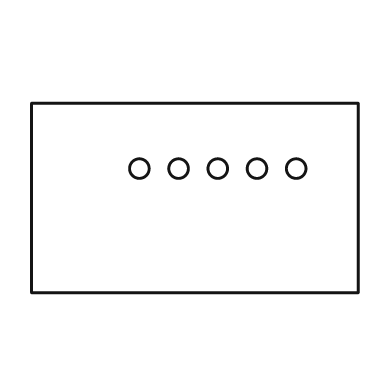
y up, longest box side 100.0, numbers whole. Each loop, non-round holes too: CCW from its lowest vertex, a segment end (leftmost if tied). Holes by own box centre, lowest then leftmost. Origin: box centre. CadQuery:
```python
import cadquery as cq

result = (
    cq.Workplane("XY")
    .moveTo(-50.0, -29.0)
    .lineTo(50.0, -29.0)
    .lineTo(50.0, 29.0)
    .lineTo(-50.0, 29.0)
    .close()
    .moveTo(-17.0, 9.0)
    .circle(3.0)
    .moveTo(-5.0, 9.0)
    .circle(3.0)
    .moveTo(7.0, 9.0)
    .circle(3.0)
    .moveTo(19.0, 9.0)
    .circle(3.0)
    .moveTo(31.0, 9.0)
    .circle(3.0)
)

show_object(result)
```